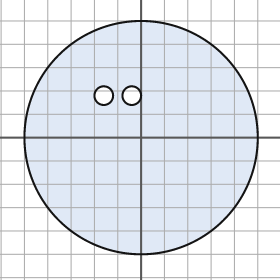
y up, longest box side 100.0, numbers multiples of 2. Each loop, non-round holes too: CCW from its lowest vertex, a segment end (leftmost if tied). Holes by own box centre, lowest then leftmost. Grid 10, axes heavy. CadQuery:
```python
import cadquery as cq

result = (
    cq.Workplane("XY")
    .moveTo(0.0, 0.0)
    .circle(50.0)
    .moveTo(-16.0, 18.0)
    .circle(4.0)
    .moveTo(-4.0, 18.0)
    .circle(4.0)
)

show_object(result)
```